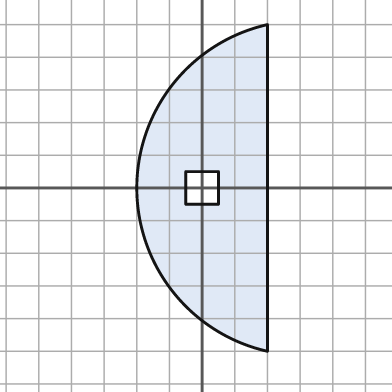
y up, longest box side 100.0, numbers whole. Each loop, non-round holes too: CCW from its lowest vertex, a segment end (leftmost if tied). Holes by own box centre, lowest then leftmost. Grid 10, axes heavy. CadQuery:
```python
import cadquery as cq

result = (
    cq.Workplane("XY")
    .moveTo(20.0, -50.0)
    .lineTo(20.0, 50.0)
    .threePointArc((-20.0, 0.0), (20.0, -50.0))
    .close()
    .moveTo(-5.0, -5.0)
    .lineTo(5.0, -5.0)
    .lineTo(5.0, 5.0)
    .lineTo(-5.0, 5.0)
    .close()
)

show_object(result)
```